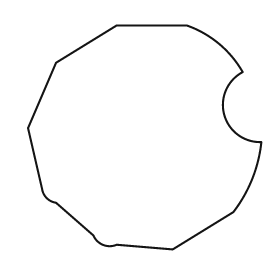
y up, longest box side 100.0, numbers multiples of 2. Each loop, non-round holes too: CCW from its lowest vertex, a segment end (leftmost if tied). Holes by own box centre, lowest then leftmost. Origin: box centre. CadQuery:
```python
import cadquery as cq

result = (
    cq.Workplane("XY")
    .moveTo(12.0, -48.0)
    .lineTo(38.0, -32.0)
    .threePointArc((46.0, -18.0), (50.0, -2.0))
    .threePointArc((34.0, 10.0), (42.0, 28.0))
    .threePointArc((32.0, 40.0), (18.0, 48.0))
    .lineTo(-12.0, 48.0)
    .lineTo(-38.0, 32.0)
    .lineTo(-50.0, 4.0)
    .lineTo(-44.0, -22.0)
    .threePointArc((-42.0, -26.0), (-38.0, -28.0))
    .lineTo(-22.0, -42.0)
    .threePointArc((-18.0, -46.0), (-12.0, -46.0))
    .close()
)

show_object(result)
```